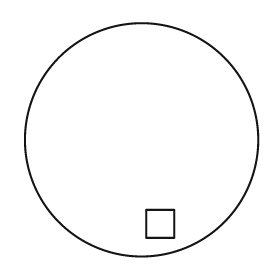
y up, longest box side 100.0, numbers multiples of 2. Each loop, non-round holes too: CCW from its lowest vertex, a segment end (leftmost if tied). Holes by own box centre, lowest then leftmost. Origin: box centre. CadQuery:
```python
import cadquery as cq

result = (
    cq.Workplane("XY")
    .moveTo(0.0, 0.0)
    .circle(50.0)
    .moveTo(2.0, -42.0)
    .lineTo(14.0, -42.0)
    .lineTo(14.0, -30.0)
    .lineTo(2.0, -30.0)
    .close()
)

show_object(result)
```